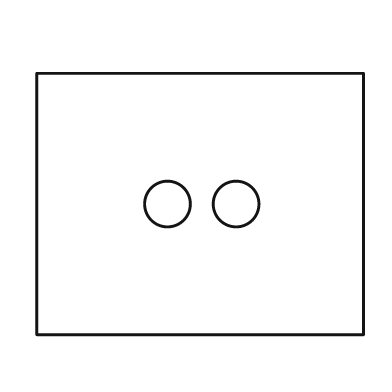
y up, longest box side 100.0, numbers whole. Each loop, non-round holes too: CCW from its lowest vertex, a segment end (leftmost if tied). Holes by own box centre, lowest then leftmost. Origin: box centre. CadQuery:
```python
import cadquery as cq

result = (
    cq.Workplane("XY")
    .moveTo(-50.0, -40.0)
    .lineTo(50.0, -40.0)
    .lineTo(50.0, 40.0)
    .lineTo(-50.0, 40.0)
    .close()
    .moveTo(-10.0, 0.0)
    .circle(7.0)
    .moveTo(11.0, 0.0)
    .circle(7.0)
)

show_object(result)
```